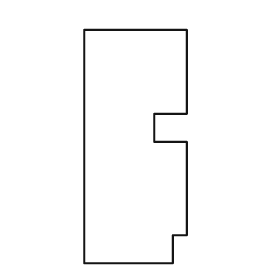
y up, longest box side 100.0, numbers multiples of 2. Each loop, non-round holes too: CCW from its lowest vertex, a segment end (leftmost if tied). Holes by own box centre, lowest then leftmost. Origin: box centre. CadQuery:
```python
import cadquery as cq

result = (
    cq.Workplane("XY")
    .moveTo(-22.0, -50.0)
    .lineTo(16.0, -50.0)
    .lineTo(16.0, -38.0)
    .lineTo(22.0, -38.0)
    .lineTo(22.0, 2.0)
    .lineTo(8.0, 2.0)
    .lineTo(8.0, 14.0)
    .lineTo(22.0, 14.0)
    .lineTo(22.0, 50.0)
    .lineTo(-22.0, 50.0)
    .close()
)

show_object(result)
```